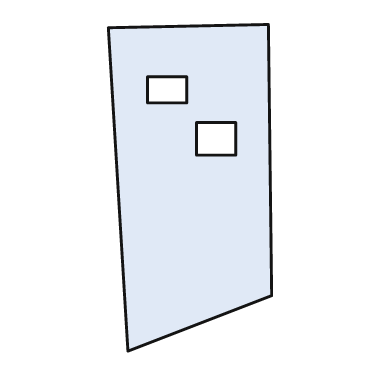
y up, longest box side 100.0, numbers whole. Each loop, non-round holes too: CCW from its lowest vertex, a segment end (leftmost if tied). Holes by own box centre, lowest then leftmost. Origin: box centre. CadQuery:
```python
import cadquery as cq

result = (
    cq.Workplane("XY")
    .moveTo(-19.0, -50.0)
    .lineTo(25.0, -33.0)
    .lineTo(24.0, 50.0)
    .lineTo(-25.0, 49.0)
    .close()
    .moveTo(2.0, 10.0)
    .lineTo(14.0, 10.0)
    .lineTo(14.0, 20.0)
    .lineTo(2.0, 20.0)
    .close()
    .moveTo(-13.0, 26.0)
    .lineTo(-1.0, 26.0)
    .lineTo(-1.0, 34.0)
    .lineTo(-13.0, 34.0)
    .close()
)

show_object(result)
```